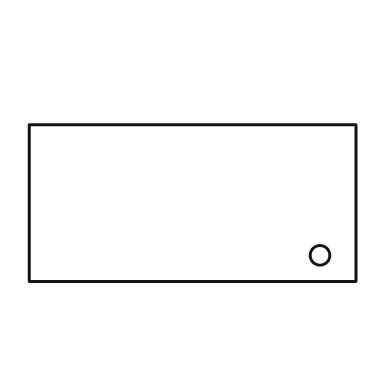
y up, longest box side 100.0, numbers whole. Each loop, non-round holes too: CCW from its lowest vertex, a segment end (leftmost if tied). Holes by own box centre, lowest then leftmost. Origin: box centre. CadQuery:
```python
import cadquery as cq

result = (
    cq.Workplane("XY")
    .moveTo(-50.0, -24.0)
    .lineTo(50.0, -24.0)
    .lineTo(50.0, 24.0)
    .lineTo(-50.0, 24.0)
    .close()
    .moveTo(39.0, -16.0)
    .circle(3.0)
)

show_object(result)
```